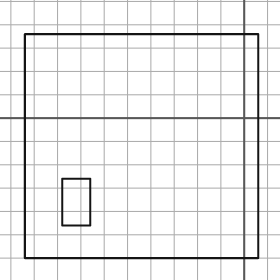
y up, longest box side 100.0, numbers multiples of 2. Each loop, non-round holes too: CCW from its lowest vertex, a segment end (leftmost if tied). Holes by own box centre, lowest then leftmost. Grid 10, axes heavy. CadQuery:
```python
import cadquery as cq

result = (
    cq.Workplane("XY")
    .moveTo(-94.0, -60.0)
    .lineTo(6.0, -60.0)
    .lineTo(6.0, 36.0)
    .lineTo(-94.0, 36.0)
    .close()
    .moveTo(-78.0, -46.0)
    .lineTo(-66.0, -46.0)
    .lineTo(-66.0, -26.0)
    .lineTo(-78.0, -26.0)
    .close()
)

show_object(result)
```